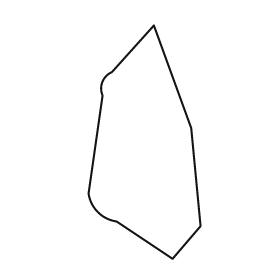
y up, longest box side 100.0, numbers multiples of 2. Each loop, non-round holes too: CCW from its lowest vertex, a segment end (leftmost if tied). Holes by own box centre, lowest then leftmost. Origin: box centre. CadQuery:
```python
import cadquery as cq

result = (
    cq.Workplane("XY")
    .moveTo(12.0, -50.0)
    .lineTo(24.0, -36.0)
    .lineTo(20.0, 6.0)
    .lineTo(4.0, 50.0)
    .lineTo(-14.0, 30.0)
    .threePointArc((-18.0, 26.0), (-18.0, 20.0))
    .lineTo(-24.0, -22.0)
    .threePointArc((-20.0, -30.0), (-12.0, -34.0))
    .close()
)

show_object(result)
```